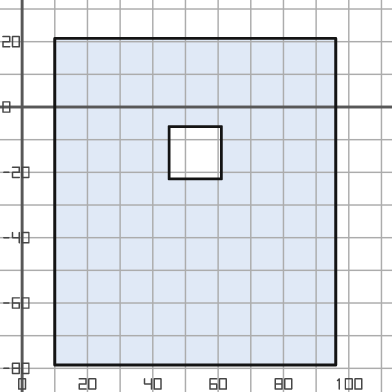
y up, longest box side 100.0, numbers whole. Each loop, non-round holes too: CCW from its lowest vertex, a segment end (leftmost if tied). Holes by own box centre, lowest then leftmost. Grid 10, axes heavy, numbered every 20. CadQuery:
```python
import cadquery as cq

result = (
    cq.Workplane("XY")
    .moveTo(10.0, -79.0)
    .lineTo(96.0, -79.0)
    .lineTo(96.0, 21.0)
    .lineTo(10.0, 21.0)
    .close()
    .moveTo(45.0, -22.0)
    .lineTo(61.0, -22.0)
    .lineTo(61.0, -6.0)
    .lineTo(45.0, -6.0)
    .close()
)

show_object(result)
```